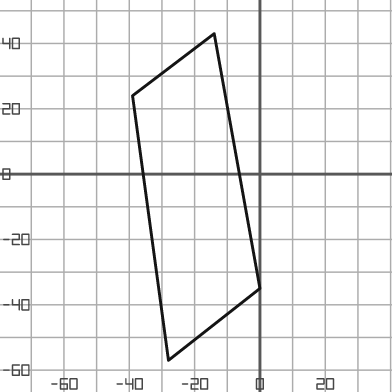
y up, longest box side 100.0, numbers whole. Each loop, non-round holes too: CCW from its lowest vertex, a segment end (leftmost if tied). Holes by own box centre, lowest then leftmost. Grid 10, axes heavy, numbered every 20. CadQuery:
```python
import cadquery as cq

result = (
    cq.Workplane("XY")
    .moveTo(-28.0, -57.0)
    .lineTo(0.0, -35.0)
    .lineTo(-14.0, 43.0)
    .lineTo(-39.0, 24.0)
    .close()
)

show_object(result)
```